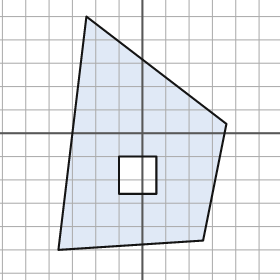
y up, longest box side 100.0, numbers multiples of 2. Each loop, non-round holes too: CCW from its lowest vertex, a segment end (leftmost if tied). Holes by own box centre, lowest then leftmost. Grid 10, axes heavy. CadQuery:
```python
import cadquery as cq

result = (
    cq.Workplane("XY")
    .moveTo(-36.0, -50.0)
    .lineTo(26.0, -46.0)
    .lineTo(36.0, 4.0)
    .lineTo(-24.0, 50.0)
    .close()
    .moveTo(-10.0, -26.0)
    .lineTo(6.0, -26.0)
    .lineTo(6.0, -10.0)
    .lineTo(-10.0, -10.0)
    .close()
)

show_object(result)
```